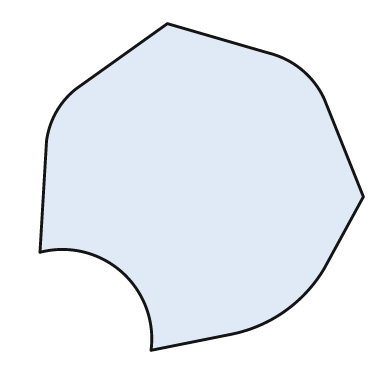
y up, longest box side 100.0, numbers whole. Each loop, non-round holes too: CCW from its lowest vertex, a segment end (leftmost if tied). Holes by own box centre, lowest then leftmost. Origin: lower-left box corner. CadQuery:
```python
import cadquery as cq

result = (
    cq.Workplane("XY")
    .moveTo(34.0, 0.0)
    .lineTo(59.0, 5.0)
    .threePointArc((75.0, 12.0), (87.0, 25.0))
    .lineTo(99.0, 47.0)
    .lineTo(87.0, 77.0)
    .threePointArc((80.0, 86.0), (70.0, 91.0))
    .lineTo(39.0, 100.0)
    .lineTo(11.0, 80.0)
    .threePointArc((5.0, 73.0), (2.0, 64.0))
    .lineTo(0.0, 30.0)
    .threePointArc((25.0, 24.0), (34.0, 0.0))
    .close()
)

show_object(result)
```